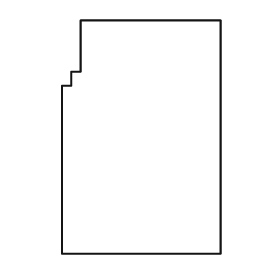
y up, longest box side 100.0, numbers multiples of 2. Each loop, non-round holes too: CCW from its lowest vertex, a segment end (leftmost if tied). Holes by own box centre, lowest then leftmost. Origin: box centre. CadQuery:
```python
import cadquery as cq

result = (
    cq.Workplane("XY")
    .moveTo(-34.0, -50.0)
    .lineTo(34.0, -50.0)
    .lineTo(34.0, 50.0)
    .lineTo(-26.0, 50.0)
    .lineTo(-26.0, 28.0)
    .lineTo(-30.0, 28.0)
    .lineTo(-30.0, 22.0)
    .lineTo(-34.0, 22.0)
    .close()
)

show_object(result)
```